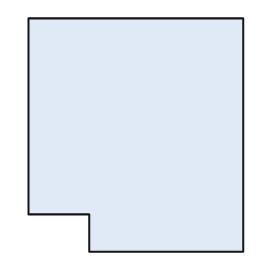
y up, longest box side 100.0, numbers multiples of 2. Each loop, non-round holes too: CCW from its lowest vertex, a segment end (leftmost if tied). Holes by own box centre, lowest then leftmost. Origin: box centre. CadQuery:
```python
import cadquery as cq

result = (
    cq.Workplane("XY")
    .moveTo(-20.0, -50.0)
    .lineTo(46.0, -50.0)
    .lineTo(46.0, 50.0)
    .lineTo(-46.0, 50.0)
    .lineTo(-46.0, -34.0)
    .lineTo(-20.0, -34.0)
    .close()
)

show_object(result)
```